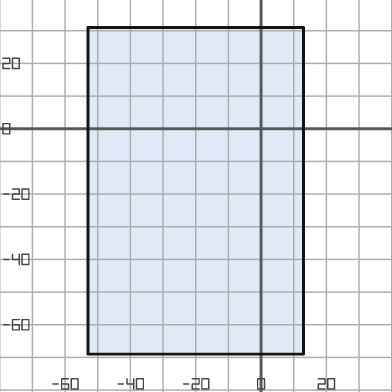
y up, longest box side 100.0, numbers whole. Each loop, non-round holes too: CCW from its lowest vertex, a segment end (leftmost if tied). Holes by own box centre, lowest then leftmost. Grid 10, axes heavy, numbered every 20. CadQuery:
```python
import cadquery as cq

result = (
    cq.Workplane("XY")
    .moveTo(-53.0, -69.0)
    .lineTo(13.0, -69.0)
    .lineTo(13.0, 31.0)
    .lineTo(-53.0, 31.0)
    .close()
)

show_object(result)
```